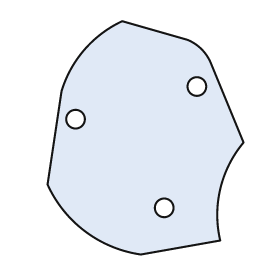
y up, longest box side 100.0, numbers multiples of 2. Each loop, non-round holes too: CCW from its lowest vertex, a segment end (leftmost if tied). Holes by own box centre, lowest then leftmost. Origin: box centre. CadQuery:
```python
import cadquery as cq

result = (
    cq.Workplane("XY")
    .moveTo(-2.0, -50.0)
    .lineTo(32.0, -44.0)
    .threePointArc((32.0, -22.0), (42.0, -2.0))
    .lineTo(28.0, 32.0)
    .threePointArc((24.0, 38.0), (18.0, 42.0))
    .lineTo(-10.0, 50.0)
    .threePointArc((-26.0, 38.0), (-36.0, 20.0))
    .lineTo(-42.0, -20.0)
    .threePointArc((-26.0, -40.0), (-2.0, -50.0))
    .close()
    .moveTo(8.0, -30.0)
    .circle(4.0)
    .moveTo(-30.0, 8.0)
    .circle(4.0)
    .moveTo(22.0, 22.0)
    .circle(4.0)
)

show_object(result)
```